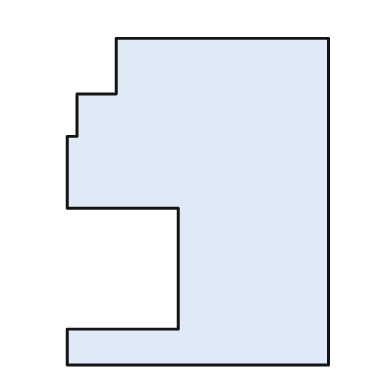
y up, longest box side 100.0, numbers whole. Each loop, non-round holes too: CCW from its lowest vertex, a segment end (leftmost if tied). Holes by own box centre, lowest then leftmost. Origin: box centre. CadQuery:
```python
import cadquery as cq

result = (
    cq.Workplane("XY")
    .moveTo(-40.0, -50.0)
    .lineTo(40.0, -50.0)
    .lineTo(40.0, 50.0)
    .lineTo(-25.0, 50.0)
    .lineTo(-25.0, 33.0)
    .lineTo(-37.0, 33.0)
    .lineTo(-37.0, 20.0)
    .lineTo(-40.0, 20.0)
    .lineTo(-40.0, -2.0)
    .lineTo(-6.0, -2.0)
    .lineTo(-6.0, -39.0)
    .lineTo(-40.0, -39.0)
    .close()
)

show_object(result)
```